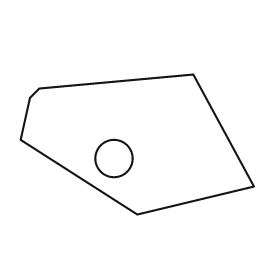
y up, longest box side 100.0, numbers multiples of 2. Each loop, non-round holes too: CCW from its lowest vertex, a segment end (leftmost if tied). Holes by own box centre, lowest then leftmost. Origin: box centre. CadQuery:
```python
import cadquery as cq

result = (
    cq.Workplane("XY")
    .moveTo(0.0, -30.0)
    .lineTo(50.0, -18.0)
    .lineTo(24.0, 30.0)
    .lineTo(-42.0, 24.0)
    .lineTo(-46.0, 20.0)
    .lineTo(-50.0, 2.0)
    .close()
    .moveTo(-10.0, -6.0)
    .circle(8.0)
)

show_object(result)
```